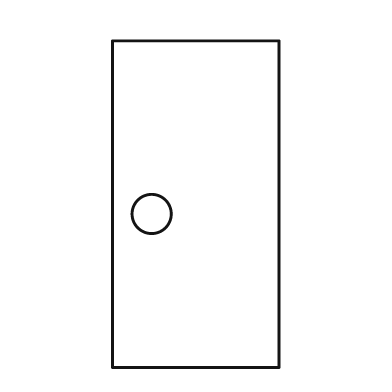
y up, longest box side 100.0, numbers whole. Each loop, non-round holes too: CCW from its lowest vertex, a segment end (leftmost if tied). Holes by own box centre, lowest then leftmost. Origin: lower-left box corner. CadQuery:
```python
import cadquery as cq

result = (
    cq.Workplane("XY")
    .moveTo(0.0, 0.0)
    .lineTo(51.0, 0.0)
    .lineTo(51.0, 100.0)
    .lineTo(0.0, 100.0)
    .close()
    .moveTo(12.0, 47.0)
    .circle(6.0)
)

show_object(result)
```